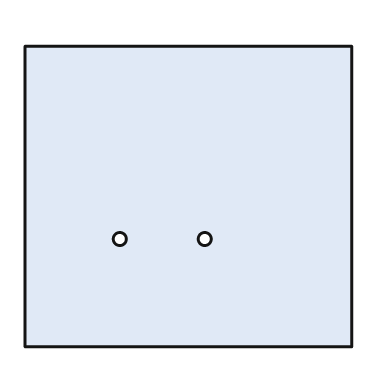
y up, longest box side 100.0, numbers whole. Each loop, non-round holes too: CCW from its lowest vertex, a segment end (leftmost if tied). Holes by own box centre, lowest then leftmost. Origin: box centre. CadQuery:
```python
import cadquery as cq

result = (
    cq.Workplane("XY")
    .moveTo(-50.0, -46.0)
    .lineTo(50.0, -46.0)
    .lineTo(50.0, 46.0)
    .lineTo(-50.0, 46.0)
    .close()
    .moveTo(-21.0, -13.0)
    .circle(2.0)
    .moveTo(5.0, -13.0)
    .circle(2.0)
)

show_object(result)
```